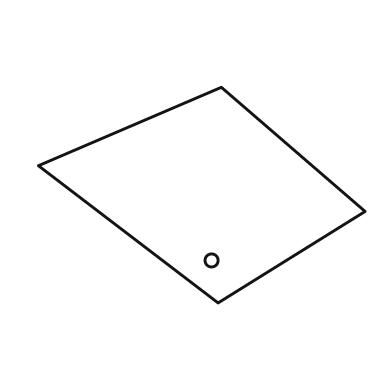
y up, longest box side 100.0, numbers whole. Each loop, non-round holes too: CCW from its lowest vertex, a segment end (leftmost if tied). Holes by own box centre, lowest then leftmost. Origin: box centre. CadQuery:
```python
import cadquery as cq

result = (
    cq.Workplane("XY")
    .moveTo(5.0, -33.0)
    .lineTo(50.0, -5.0)
    .lineTo(6.0, 33.0)
    .lineTo(-50.0, 9.0)
    .close()
    .moveTo(3.0, -20.0)
    .circle(2.0)
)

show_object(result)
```